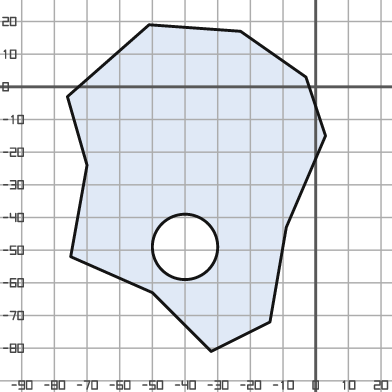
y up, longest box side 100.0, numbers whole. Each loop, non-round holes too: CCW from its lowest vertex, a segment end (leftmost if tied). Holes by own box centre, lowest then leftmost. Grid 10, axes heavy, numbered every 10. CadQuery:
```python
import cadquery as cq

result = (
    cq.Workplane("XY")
    .moveTo(-32.0, -81.0)
    .lineTo(-14.0, -72.0)
    .lineTo(-9.0, -43.0)
    .lineTo(3.0, -15.0)
    .lineTo(-3.0, 3.0)
    .lineTo(-23.0, 17.0)
    .lineTo(-51.0, 19.0)
    .lineTo(-76.0, -3.0)
    .lineTo(-70.0, -24.0)
    .lineTo(-75.0, -52.0)
    .lineTo(-50.0, -63.0)
    .close()
    .moveTo(-40.0, -49.0)
    .circle(10.0)
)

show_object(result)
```